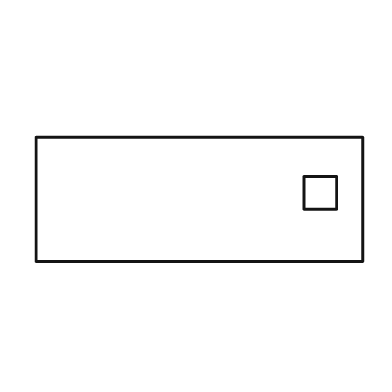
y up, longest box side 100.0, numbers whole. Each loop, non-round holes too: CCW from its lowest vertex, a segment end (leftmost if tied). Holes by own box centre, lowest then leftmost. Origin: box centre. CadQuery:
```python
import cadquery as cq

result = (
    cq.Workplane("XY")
    .moveTo(-50.0, -19.0)
    .lineTo(50.0, -19.0)
    .lineTo(50.0, 19.0)
    .lineTo(-50.0, 19.0)
    .close()
    .moveTo(32.0, -3.0)
    .lineTo(42.0, -3.0)
    .lineTo(42.0, 7.0)
    .lineTo(32.0, 7.0)
    .close()
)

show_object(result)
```